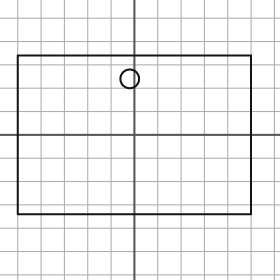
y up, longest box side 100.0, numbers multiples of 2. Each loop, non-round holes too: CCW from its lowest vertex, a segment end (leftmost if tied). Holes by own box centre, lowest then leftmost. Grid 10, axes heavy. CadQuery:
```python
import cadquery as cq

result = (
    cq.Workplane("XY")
    .moveTo(-50.0, -34.0)
    .lineTo(50.0, -34.0)
    .lineTo(50.0, 34.0)
    .lineTo(-50.0, 34.0)
    .close()
    .moveTo(-2.0, 24.0)
    .circle(4.0)
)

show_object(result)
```